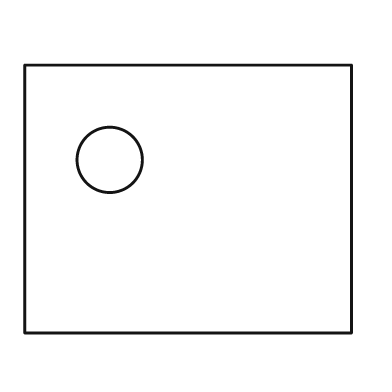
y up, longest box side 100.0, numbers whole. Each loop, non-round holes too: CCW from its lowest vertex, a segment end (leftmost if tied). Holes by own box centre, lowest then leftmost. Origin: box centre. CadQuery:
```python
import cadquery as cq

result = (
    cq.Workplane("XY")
    .moveTo(-50.0, -41.0)
    .lineTo(50.0, -41.0)
    .lineTo(50.0, 41.0)
    .lineTo(-50.0, 41.0)
    .close()
    .moveTo(-24.0, 12.0)
    .circle(10.0)
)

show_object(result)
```